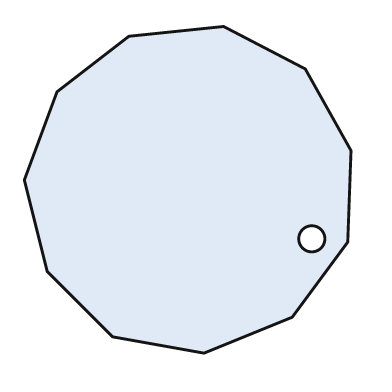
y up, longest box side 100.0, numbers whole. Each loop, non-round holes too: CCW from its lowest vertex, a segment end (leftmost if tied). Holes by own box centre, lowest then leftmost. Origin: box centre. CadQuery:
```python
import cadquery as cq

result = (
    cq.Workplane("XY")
    .moveTo(5.0, -50.0)
    .lineTo(32.0, -39.0)
    .lineTo(49.0, -16.0)
    .lineTo(50.0, 12.0)
    .lineTo(36.0, 37.0)
    .lineTo(11.0, 50.0)
    .lineTo(-18.0, 47.0)
    .lineTo(-40.0, 30.0)
    .lineTo(-50.0, 3.0)
    .lineTo(-43.0, -25.0)
    .lineTo(-23.0, -45.0)
    .close()
    .moveTo(38.0, -15.0)
    .circle(4.0)
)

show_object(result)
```